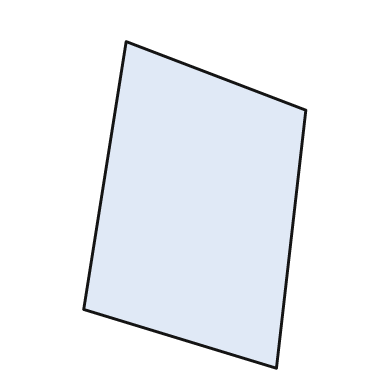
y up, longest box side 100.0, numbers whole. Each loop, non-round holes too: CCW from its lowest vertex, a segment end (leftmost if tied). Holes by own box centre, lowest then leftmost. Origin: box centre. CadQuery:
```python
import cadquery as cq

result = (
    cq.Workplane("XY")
    .moveTo(25.0, -50.0)
    .lineTo(34.0, 29.0)
    .lineTo(-21.0, 50.0)
    .lineTo(-34.0, -32.0)
    .close()
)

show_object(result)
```